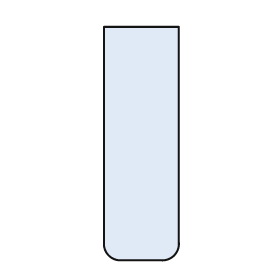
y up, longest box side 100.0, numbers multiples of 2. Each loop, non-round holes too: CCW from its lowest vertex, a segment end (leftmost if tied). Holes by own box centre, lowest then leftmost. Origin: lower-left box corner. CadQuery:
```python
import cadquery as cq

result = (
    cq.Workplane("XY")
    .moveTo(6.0, 0.0)
    .lineTo(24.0, 0.0)
    .threePointArc((30.0, 2.0), (32.0, 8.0))
    .lineTo(32.0, 100.0)
    .lineTo(0.0, 100.0)
    .lineTo(0.0, 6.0)
    .threePointArc((2.0, 2.0), (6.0, 0.0))
    .close()
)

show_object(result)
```